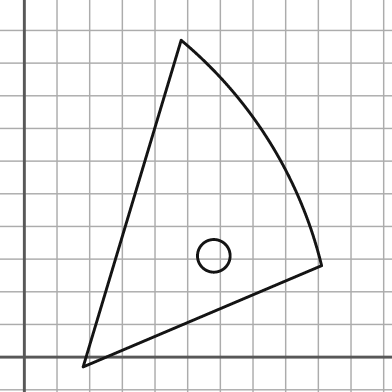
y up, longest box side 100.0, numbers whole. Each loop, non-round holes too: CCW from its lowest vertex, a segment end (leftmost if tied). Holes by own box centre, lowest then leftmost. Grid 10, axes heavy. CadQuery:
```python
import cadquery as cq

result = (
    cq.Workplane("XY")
    .moveTo(18.0, -3.0)
    .lineTo(91.0, 28.0)
    .threePointArc((75.0, 66.0), (48.0, 97.0))
    .close()
    .moveTo(58.0, 31.0)
    .circle(5.0)
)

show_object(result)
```